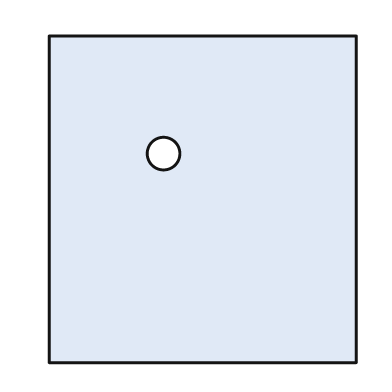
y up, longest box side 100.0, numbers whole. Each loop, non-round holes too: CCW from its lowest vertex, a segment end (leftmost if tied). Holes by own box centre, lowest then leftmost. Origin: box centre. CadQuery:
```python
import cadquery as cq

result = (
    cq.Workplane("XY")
    .moveTo(-47.0, -50.0)
    .lineTo(47.0, -50.0)
    .lineTo(47.0, 50.0)
    .lineTo(-47.0, 50.0)
    .close()
    .moveTo(-12.0, 14.0)
    .circle(5.0)
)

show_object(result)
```